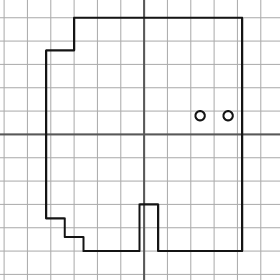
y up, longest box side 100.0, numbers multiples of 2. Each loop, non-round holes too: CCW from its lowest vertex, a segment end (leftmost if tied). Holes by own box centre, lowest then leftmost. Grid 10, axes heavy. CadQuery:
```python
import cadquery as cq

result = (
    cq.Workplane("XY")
    .moveTo(-26.0, -50.0)
    .lineTo(-2.0, -50.0)
    .lineTo(-2.0, -30.0)
    .lineTo(6.0, -30.0)
    .lineTo(6.0, -50.0)
    .lineTo(42.0, -50.0)
    .lineTo(42.0, 50.0)
    .lineTo(-30.0, 50.0)
    .lineTo(-30.0, 36.0)
    .lineTo(-42.0, 36.0)
    .lineTo(-42.0, -36.0)
    .lineTo(-34.0, -36.0)
    .lineTo(-34.0, -44.0)
    .lineTo(-26.0, -44.0)
    .close()
    .moveTo(24.0, 8.0)
    .circle(2.0)
    .moveTo(36.0, 8.0)
    .circle(2.0)
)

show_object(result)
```